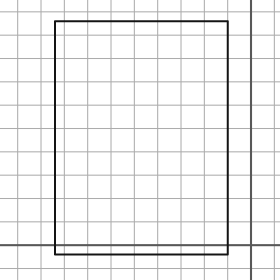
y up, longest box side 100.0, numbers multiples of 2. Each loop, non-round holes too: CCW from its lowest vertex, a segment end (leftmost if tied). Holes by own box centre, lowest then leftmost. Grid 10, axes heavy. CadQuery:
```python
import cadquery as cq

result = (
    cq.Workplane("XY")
    .moveTo(-84.0, -4.0)
    .lineTo(-10.0, -4.0)
    .lineTo(-10.0, 96.0)
    .lineTo(-84.0, 96.0)
    .close()
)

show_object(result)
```